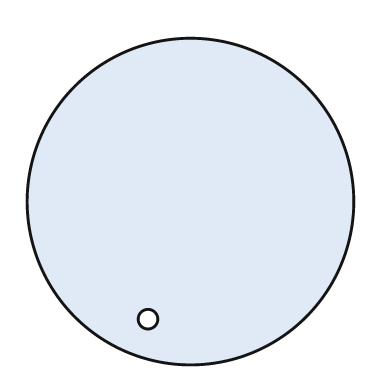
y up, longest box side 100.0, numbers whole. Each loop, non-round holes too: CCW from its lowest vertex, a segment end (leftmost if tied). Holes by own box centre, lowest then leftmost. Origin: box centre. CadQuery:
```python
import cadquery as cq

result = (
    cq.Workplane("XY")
    .moveTo(0.0, 0.0)
    .circle(50.0)
    .moveTo(-13.0, -36.0)
    .circle(3.0)
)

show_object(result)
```